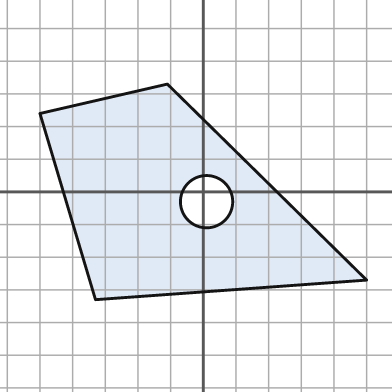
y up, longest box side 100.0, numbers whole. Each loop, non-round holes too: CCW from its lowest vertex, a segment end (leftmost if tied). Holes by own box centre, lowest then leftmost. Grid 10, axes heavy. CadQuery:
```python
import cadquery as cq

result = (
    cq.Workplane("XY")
    .moveTo(-33.0, -33.0)
    .lineTo(50.0, -27.0)
    .lineTo(-11.0, 33.0)
    .lineTo(-50.0, 24.0)
    .close()
    .moveTo(1.0, -3.0)
    .circle(8.0)
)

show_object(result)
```